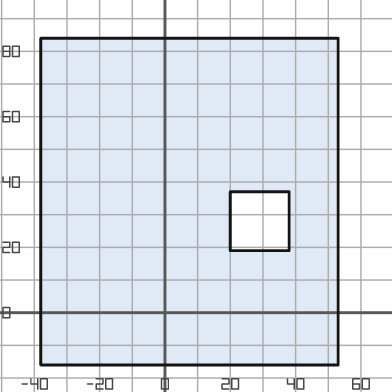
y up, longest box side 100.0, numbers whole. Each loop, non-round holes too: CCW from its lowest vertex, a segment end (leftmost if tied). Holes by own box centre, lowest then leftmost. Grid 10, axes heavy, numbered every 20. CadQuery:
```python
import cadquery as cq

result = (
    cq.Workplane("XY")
    .moveTo(-38.0, -16.0)
    .lineTo(53.0, -16.0)
    .lineTo(53.0, 84.0)
    .lineTo(-38.0, 84.0)
    .close()
    .moveTo(20.0, 19.0)
    .lineTo(38.0, 19.0)
    .lineTo(38.0, 37.0)
    .lineTo(20.0, 37.0)
    .close()
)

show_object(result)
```